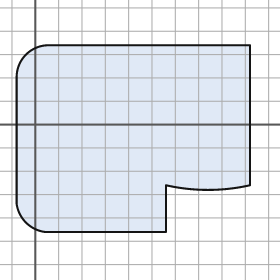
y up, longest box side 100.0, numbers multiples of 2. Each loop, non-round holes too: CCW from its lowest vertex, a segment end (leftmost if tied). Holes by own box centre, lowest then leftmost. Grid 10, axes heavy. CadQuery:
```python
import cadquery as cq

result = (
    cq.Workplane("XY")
    .moveTo(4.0, -46.0)
    .lineTo(56.0, -46.0)
    .lineTo(56.0, -26.0)
    .threePointArc((74.0, -28.0), (92.0, -26.0))
    .lineTo(92.0, 34.0)
    .lineTo(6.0, 34.0)
    .threePointArc((-4.0, 30.0), (-8.0, 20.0))
    .lineTo(-8.0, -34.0)
    .threePointArc((-4.0, -42.0), (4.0, -46.0))
    .close()
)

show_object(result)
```